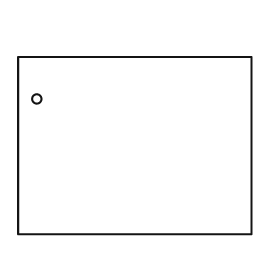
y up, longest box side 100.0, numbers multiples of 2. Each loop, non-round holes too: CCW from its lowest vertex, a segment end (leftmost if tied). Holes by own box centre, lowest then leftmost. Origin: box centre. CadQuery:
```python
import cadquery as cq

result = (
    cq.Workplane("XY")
    .moveTo(-50.0, -38.0)
    .lineTo(50.0, -38.0)
    .lineTo(50.0, 38.0)
    .lineTo(-50.0, 38.0)
    .close()
    .moveTo(-42.0, 20.0)
    .circle(2.0)
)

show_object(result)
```